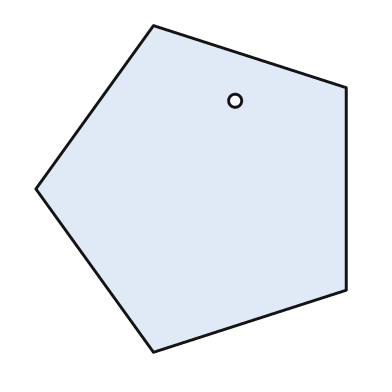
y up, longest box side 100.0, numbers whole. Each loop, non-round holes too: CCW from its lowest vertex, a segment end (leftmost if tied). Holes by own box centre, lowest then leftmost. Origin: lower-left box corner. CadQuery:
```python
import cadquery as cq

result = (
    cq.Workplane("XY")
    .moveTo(36.0, 0.0)
    .lineTo(95.0, 19.0)
    .lineTo(95.0, 81.0)
    .lineTo(36.0, 100.0)
    .lineTo(0.0, 50.0)
    .close()
    .moveTo(61.0, 77.0)
    .circle(2.0)
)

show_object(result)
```